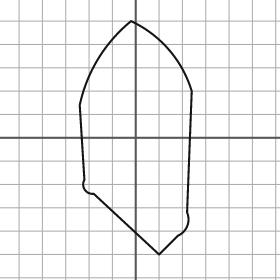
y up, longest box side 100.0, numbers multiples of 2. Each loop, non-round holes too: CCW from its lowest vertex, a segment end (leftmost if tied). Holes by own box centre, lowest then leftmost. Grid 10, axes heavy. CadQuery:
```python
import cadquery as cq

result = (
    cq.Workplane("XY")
    .moveTo(10.0, -50.0)
    .lineTo(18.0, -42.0)
    .threePointArc((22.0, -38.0), (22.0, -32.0))
    .lineTo(24.0, 20.0)
    .threePointArc((14.0, 38.0), (-2.0, 50.0))
    .threePointArc((-16.0, 34.0), (-24.0, 14.0))
    .lineTo(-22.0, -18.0)
    .threePointArc((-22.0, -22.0), (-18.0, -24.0))
    .close()
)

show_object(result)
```